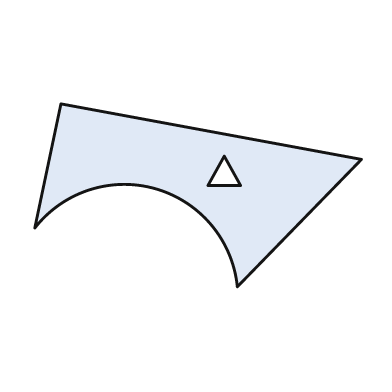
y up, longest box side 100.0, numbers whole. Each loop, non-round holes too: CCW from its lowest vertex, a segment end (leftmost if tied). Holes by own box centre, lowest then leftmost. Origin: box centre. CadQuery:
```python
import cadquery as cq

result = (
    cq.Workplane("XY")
    .moveTo(12.0, -28.0)
    .lineTo(50.0, 11.0)
    .lineTo(-42.0, 28.0)
    .lineTo(-50.0, -10.0)
    .threePointArc((-13.0, 2.0), (12.0, -28.0))
    .close()
    .moveTo(3.0, 3.0)
    .lineTo(13.0, 3.0)
    .lineTo(8.0, 12.0)
    .close()
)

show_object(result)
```